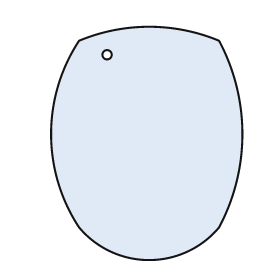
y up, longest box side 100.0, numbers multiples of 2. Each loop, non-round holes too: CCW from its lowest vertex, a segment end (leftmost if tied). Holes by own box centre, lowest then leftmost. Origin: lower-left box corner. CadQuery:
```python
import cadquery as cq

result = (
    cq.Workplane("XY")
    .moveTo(12.0, 14.0)
    .threePointArc((42.0, 0.0), (72.0, 14.0))
    .threePointArc((82.0, 54.0), (72.0, 94.0))
    .threePointArc((42.0, 100.0), (12.0, 94.0))
    .threePointArc((0.0, 54.0), (12.0, 14.0))
    .close()
    .moveTo(24.0, 88.0)
    .circle(2.0)
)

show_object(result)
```